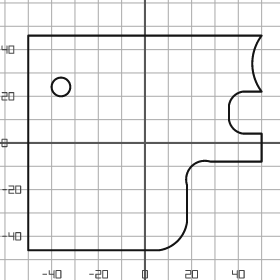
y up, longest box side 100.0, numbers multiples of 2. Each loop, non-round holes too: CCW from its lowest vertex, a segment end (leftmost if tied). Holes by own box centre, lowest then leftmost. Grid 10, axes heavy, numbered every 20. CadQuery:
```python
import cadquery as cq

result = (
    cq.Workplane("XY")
    .moveTo(-50.0, -46.0)
    .lineTo(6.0, -46.0)
    .threePointArc((14.0, -42.0), (18.0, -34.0))
    .lineTo(18.0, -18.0)
    .threePointArc((20.0, -10.0), (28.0, -8.0))
    .lineTo(50.0, -8.0)
    .lineTo(50.0, 4.0)
    .lineTo(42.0, 4.0)
    .threePointArc((38.0, 6.0), (36.0, 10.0))
    .lineTo(36.0, 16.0)
    .threePointArc((38.0, 20.0), (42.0, 22.0))
    .lineTo(50.0, 22.0)
    .threePointArc((46.0, 34.0), (50.0, 46.0))
    .lineTo(-50.0, 46.0)
    .close()
    .moveTo(-36.0, 24.0)
    .circle(4.0)
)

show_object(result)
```